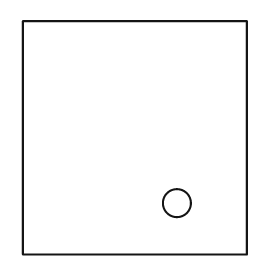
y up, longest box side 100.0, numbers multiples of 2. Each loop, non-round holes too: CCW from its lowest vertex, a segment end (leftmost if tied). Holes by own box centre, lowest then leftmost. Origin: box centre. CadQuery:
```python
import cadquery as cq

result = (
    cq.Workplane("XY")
    .moveTo(-48.0, -50.0)
    .lineTo(48.0, -50.0)
    .lineTo(48.0, 50.0)
    .lineTo(-48.0, 50.0)
    .close()
    .moveTo(18.0, -28.0)
    .circle(6.0)
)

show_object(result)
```